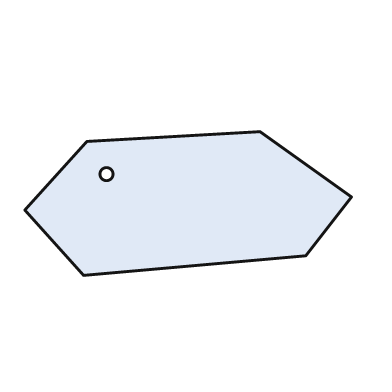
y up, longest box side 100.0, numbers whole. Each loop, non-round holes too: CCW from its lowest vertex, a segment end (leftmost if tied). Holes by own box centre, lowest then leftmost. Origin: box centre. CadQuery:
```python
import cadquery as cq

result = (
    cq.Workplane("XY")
    .moveTo(-32.0, -22.0)
    .lineTo(36.0, -16.0)
    .lineTo(50.0, 2.0)
    .lineTo(22.0, 22.0)
    .lineTo(-31.0, 19.0)
    .lineTo(-50.0, -2.0)
    .close()
    .moveTo(-25.0, 9.0)
    .circle(2.0)
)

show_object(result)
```